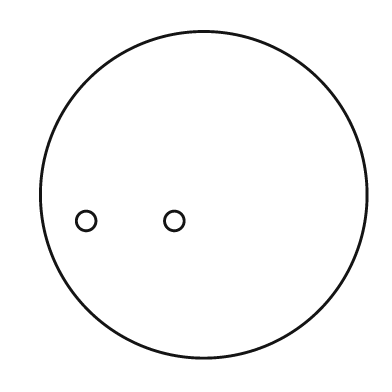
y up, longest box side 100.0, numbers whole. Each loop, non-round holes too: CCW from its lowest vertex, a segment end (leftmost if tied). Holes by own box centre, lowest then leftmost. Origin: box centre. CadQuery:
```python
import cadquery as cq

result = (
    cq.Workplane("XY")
    .moveTo(0.0, 0.0)
    .circle(50.0)
    .moveTo(-36.0, -8.0)
    .circle(3.0)
    .moveTo(-9.0, -8.0)
    .circle(3.0)
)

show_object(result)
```